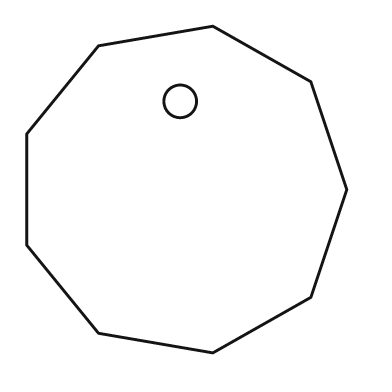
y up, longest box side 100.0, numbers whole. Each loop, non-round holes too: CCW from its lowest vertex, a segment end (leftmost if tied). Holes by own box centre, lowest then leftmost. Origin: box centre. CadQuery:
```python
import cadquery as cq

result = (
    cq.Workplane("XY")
    .moveTo(8.0, -50.0)
    .lineTo(38.0, -33.0)
    .lineTo(49.0, 0.0)
    .lineTo(38.0, 33.0)
    .lineTo(8.0, 50.0)
    .lineTo(-27.0, 44.0)
    .lineTo(-49.0, 17.0)
    .lineTo(-49.0, -17.0)
    .lineTo(-27.0, -44.0)
    .close()
    .moveTo(-2.0, 27.0)
    .circle(5.0)
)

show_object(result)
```